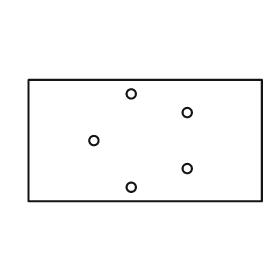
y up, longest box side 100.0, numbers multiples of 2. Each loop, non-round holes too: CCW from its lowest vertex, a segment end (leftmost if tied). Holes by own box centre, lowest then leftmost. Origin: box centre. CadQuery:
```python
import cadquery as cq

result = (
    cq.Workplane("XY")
    .moveTo(-50.0, -26.0)
    .lineTo(50.0, -26.0)
    .lineTo(50.0, 26.0)
    .lineTo(-50.0, 26.0)
    .close()
    .moveTo(-6.0, -20.0)
    .circle(2.0)
    .moveTo(18.0, -12.0)
    .circle(2.0)
    .moveTo(-22.0, 0.0)
    .circle(2.0)
    .moveTo(18.0, 12.0)
    .circle(2.0)
    .moveTo(-6.0, 20.0)
    .circle(2.0)
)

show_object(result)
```